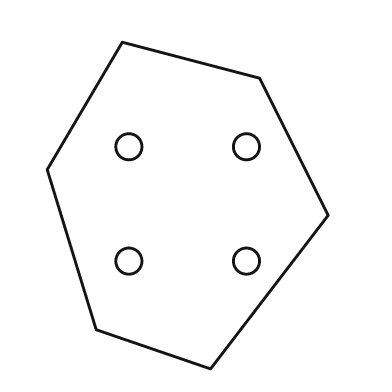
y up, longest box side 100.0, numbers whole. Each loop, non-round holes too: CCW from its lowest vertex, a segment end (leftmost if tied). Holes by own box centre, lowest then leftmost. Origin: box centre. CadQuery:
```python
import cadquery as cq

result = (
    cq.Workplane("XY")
    .moveTo(7.0, -50.0)
    .lineTo(43.0, -3.0)
    .lineTo(22.0, 39.0)
    .lineTo(-20.0, 50.0)
    .lineTo(-43.0, 11.0)
    .lineTo(-28.0, -38.0)
    .close()
    .moveTo(-18.0, -17.0)
    .circle(4.0)
    .moveTo(18.0, -17.0)
    .circle(4.0)
    .moveTo(-18.0, 18.0)
    .circle(4.0)
    .moveTo(18.0, 18.0)
    .circle(4.0)
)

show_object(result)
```